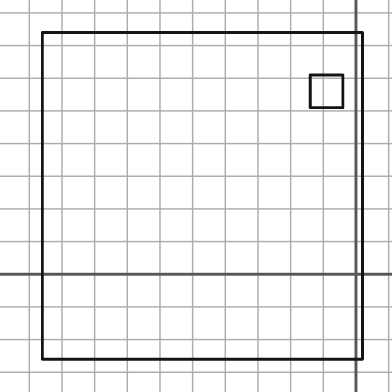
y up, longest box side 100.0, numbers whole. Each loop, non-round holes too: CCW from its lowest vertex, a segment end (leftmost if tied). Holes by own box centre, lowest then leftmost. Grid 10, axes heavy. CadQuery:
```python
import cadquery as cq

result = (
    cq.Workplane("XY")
    .moveTo(-96.0, -26.0)
    .lineTo(2.0, -26.0)
    .lineTo(2.0, 74.0)
    .lineTo(-96.0, 74.0)
    .close()
    .moveTo(-14.0, 51.0)
    .lineTo(-4.0, 51.0)
    .lineTo(-4.0, 61.0)
    .lineTo(-14.0, 61.0)
    .close()
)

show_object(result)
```